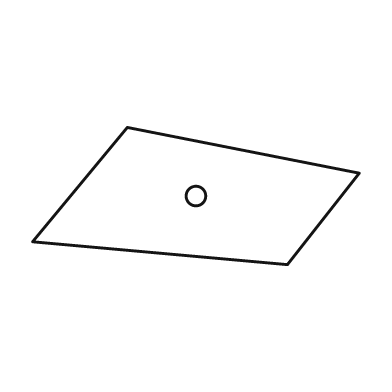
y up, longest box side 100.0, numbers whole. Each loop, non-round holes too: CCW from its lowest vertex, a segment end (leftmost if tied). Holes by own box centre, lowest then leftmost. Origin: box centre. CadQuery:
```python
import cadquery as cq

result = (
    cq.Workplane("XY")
    .moveTo(28.0, -21.0)
    .lineTo(50.0, 7.0)
    .lineTo(-21.0, 21.0)
    .lineTo(-50.0, -14.0)
    .close()
    .moveTo(0.0, 0.0)
    .circle(3.0)
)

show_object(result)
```